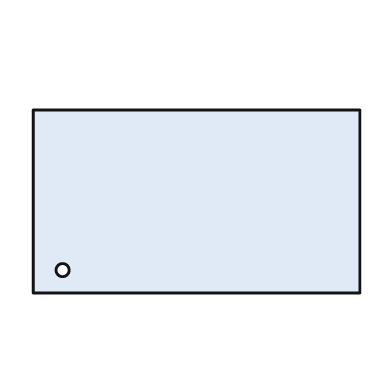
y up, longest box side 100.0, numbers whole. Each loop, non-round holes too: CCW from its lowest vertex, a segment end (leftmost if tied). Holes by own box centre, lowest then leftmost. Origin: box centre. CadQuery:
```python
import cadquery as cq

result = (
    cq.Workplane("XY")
    .moveTo(-50.0, -28.0)
    .lineTo(50.0, -28.0)
    .lineTo(50.0, 28.0)
    .lineTo(-50.0, 28.0)
    .close()
    .moveTo(-41.0, -21.0)
    .circle(2.0)
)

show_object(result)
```